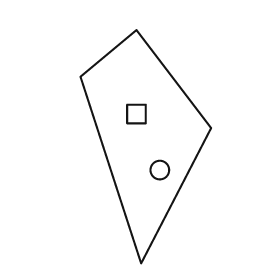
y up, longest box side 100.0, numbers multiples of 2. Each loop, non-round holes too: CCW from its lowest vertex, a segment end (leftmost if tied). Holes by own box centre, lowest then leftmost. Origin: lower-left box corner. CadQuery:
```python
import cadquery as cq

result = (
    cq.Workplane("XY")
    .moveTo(26.0, 0.0)
    .lineTo(56.0, 58.0)
    .lineTo(24.0, 100.0)
    .lineTo(0.0, 80.0)
    .close()
    .moveTo(34.0, 40.0)
    .circle(4.0)
    .moveTo(20.0, 60.0)
    .lineTo(28.0, 60.0)
    .lineTo(28.0, 68.0)
    .lineTo(20.0, 68.0)
    .close()
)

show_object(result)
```